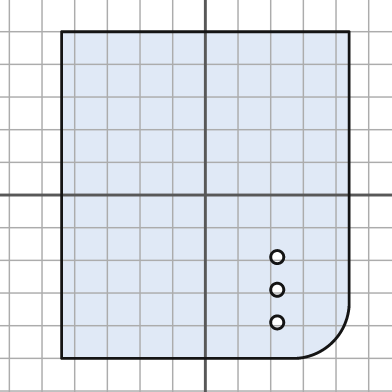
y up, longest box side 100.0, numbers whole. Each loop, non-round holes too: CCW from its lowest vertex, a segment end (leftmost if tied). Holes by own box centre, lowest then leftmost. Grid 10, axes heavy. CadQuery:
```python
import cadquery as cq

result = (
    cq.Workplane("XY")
    .moveTo(-44.0, -50.0)
    .lineTo(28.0, -50.0)
    .threePointArc((39.0, -45.0), (44.0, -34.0))
    .lineTo(44.0, 50.0)
    .lineTo(-44.0, 50.0)
    .close()
    .moveTo(22.0, -39.0)
    .circle(2.0)
    .moveTo(22.0, -29.0)
    .circle(2.0)
    .moveTo(22.0, -19.0)
    .circle(2.0)
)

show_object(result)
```